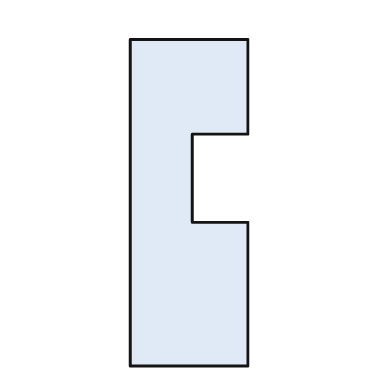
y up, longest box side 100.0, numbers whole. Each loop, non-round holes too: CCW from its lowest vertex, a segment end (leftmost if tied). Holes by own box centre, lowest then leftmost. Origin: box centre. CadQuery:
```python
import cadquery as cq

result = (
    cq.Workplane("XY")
    .moveTo(-18.0, -50.0)
    .lineTo(18.0, -50.0)
    .lineTo(18.0, -6.0)
    .lineTo(1.0, -6.0)
    .lineTo(1.0, 21.0)
    .lineTo(18.0, 21.0)
    .lineTo(18.0, 50.0)
    .lineTo(-18.0, 50.0)
    .close()
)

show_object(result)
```